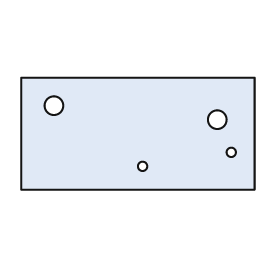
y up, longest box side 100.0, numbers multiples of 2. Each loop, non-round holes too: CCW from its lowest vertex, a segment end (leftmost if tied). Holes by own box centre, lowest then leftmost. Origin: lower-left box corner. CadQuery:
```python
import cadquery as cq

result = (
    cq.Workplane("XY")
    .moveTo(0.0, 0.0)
    .lineTo(100.0, 0.0)
    .lineTo(100.0, 48.0)
    .lineTo(0.0, 48.0)
    .close()
    .moveTo(52.0, 10.0)
    .circle(2.0)
    .moveTo(90.0, 16.0)
    .circle(2.0)
    .moveTo(84.0, 30.0)
    .circle(4.0)
    .moveTo(14.0, 36.0)
    .circle(4.0)
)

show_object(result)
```